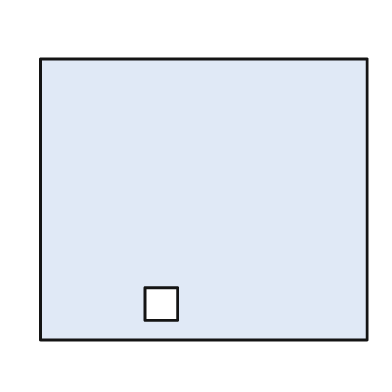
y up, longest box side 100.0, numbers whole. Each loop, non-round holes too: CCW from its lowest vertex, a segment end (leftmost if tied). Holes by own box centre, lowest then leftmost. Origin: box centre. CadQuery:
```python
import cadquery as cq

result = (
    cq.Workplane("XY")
    .moveTo(-50.0, -43.0)
    .lineTo(50.0, -43.0)
    .lineTo(50.0, 43.0)
    .lineTo(-50.0, 43.0)
    .close()
    .moveTo(-18.0, -37.0)
    .lineTo(-8.0, -37.0)
    .lineTo(-8.0, -27.0)
    .lineTo(-18.0, -27.0)
    .close()
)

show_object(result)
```